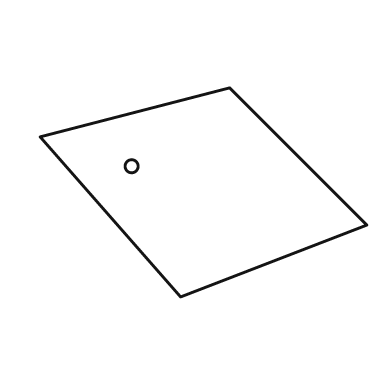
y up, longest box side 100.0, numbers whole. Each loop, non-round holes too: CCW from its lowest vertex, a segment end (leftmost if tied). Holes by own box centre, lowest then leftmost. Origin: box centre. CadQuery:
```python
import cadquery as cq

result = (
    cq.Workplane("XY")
    .moveTo(-7.0, -32.0)
    .lineTo(50.0, -10.0)
    .lineTo(8.0, 32.0)
    .lineTo(-50.0, 17.0)
    .close()
    .moveTo(-22.0, 8.0)
    .circle(2.0)
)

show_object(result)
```